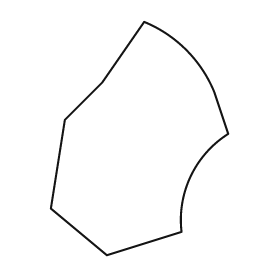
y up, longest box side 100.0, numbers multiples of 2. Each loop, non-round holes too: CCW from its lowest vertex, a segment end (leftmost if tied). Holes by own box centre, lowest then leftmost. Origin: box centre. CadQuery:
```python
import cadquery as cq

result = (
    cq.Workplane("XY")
    .moveTo(-14.0, -50.0)
    .lineTo(18.0, -40.0)
    .threePointArc((22.0, -16.0), (38.0, 2.0))
    .lineTo(32.0, 20.0)
    .threePointArc((20.0, 38.0), (2.0, 50.0))
    .lineTo(-16.0, 24.0)
    .lineTo(-32.0, 8.0)
    .lineTo(-38.0, -30.0)
    .close()
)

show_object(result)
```